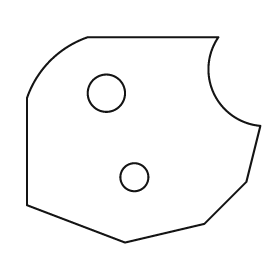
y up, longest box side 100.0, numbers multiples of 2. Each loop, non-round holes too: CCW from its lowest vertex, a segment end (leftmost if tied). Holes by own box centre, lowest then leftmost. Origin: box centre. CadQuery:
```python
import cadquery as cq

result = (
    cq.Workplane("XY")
    .moveTo(-8.0, -44.0)
    .lineTo(26.0, -36.0)
    .lineTo(44.0, -18.0)
    .lineTo(50.0, 6.0)
    .threePointArc((30.0, 20.0), (32.0, 44.0))
    .lineTo(-24.0, 44.0)
    .threePointArc((-40.0, 34.0), (-50.0, 18.0))
    .lineTo(-50.0, -28.0)
    .close()
    .moveTo(-4.0, -16.0)
    .circle(6.0)
    .moveTo(-16.0, 20.0)
    .circle(8.0)
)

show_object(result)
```